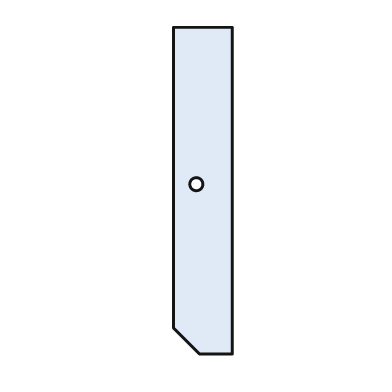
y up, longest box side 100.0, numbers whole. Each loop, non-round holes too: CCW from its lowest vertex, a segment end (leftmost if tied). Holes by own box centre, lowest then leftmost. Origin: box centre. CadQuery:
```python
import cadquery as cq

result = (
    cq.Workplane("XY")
    .moveTo(-1.0, -50.0)
    .lineTo(9.0, -50.0)
    .lineTo(9.0, 50.0)
    .lineTo(-9.0, 50.0)
    .lineTo(-9.0, -42.0)
    .close()
    .moveTo(-2.0, 2.0)
    .circle(2.0)
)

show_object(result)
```